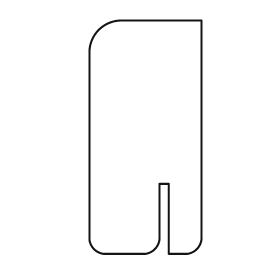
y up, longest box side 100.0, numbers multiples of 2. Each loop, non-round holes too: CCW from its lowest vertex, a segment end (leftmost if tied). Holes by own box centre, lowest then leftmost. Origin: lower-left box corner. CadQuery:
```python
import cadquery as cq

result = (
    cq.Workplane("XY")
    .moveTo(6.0, 0.0)
    .lineTo(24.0, 0.0)
    .threePointArc((28.0, 2.0), (30.0, 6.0))
    .lineTo(30.0, 30.0)
    .lineTo(34.0, 30.0)
    .lineTo(34.0, 0.0)
    .lineTo(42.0, 0.0)
    .threePointArc((46.0, 2.0), (48.0, 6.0))
    .lineTo(48.0, 100.0)
    .lineTo(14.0, 100.0)
    .threePointArc((4.0, 96.0), (0.0, 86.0))
    .lineTo(0.0, 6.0)
    .threePointArc((2.0, 2.0), (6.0, 0.0))
    .close()
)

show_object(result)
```